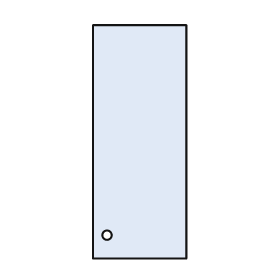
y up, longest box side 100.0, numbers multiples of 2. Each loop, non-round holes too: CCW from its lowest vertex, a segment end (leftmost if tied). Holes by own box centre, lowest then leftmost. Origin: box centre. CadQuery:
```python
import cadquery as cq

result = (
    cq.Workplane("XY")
    .moveTo(-20.0, -50.0)
    .lineTo(20.0, -50.0)
    .lineTo(20.0, 50.0)
    .lineTo(-20.0, 50.0)
    .close()
    .moveTo(-14.0, -40.0)
    .circle(2.0)
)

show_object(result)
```